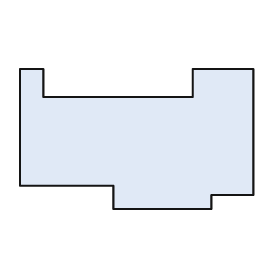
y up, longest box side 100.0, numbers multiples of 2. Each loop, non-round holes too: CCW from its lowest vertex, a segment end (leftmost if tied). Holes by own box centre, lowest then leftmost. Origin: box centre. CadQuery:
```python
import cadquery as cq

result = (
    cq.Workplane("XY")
    .moveTo(-10.0, -30.0)
    .lineTo(32.0, -30.0)
    .lineTo(32.0, -24.0)
    .lineTo(50.0, -24.0)
    .lineTo(50.0, 30.0)
    .lineTo(24.0, 30.0)
    .lineTo(24.0, 18.0)
    .lineTo(-40.0, 18.0)
    .lineTo(-40.0, 30.0)
    .lineTo(-50.0, 30.0)
    .lineTo(-50.0, -20.0)
    .lineTo(-10.0, -20.0)
    .close()
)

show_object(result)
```